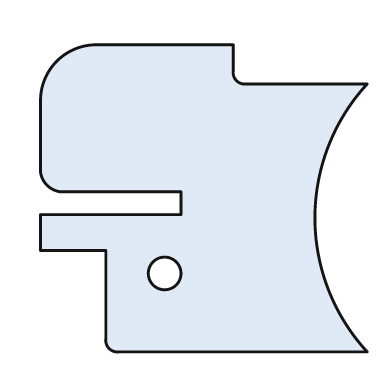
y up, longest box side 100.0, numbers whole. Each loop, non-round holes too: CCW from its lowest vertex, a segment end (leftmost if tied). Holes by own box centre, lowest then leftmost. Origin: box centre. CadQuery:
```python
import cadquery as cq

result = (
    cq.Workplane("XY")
    .moveTo(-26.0, -47.0)
    .lineTo(50.0, -47.0)
    .threePointArc((34.0, -6.0), (50.0, 35.0))
    .lineTo(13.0, 35.0)
    .threePointArc((10.0, 36.0), (9.0, 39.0))
    .lineTo(9.0, 47.0)
    .lineTo(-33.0, 47.0)
    .threePointArc((-45.0, 42.0), (-50.0, 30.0))
    .lineTo(-50.0, 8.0)
    .threePointArc((-48.0, 4.0), (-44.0, 2.0))
    .lineTo(-7.0, 2.0)
    .lineTo(-7.0, -5.0)
    .lineTo(-50.0, -5.0)
    .lineTo(-50.0, -16.0)
    .lineTo(-30.0, -16.0)
    .lineTo(-30.0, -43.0)
    .threePointArc((-29.0, -46.0), (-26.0, -47.0))
    .close()
    .moveTo(-12.0, -23.0)
    .circle(5.0)
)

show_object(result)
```